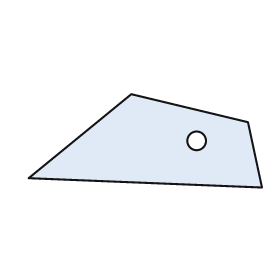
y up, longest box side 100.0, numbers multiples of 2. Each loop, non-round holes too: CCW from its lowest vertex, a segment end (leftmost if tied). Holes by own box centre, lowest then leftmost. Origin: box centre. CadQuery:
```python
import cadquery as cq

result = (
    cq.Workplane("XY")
    .moveTo(50.0, -20.0)
    .lineTo(44.0, 8.0)
    .lineTo(-6.0, 20.0)
    .lineTo(-50.0, -16.0)
    .close()
    .moveTo(22.0, 0.0)
    .circle(4.0)
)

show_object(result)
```